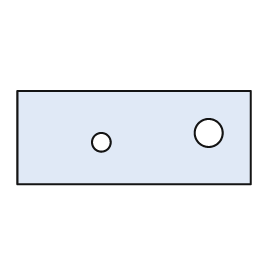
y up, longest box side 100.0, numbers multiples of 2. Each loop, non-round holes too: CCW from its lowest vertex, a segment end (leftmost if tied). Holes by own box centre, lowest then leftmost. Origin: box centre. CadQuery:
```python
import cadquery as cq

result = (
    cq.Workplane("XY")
    .moveTo(-50.0, -20.0)
    .lineTo(50.0, -20.0)
    .lineTo(50.0, 20.0)
    .lineTo(-50.0, 20.0)
    .close()
    .moveTo(-14.0, -2.0)
    .circle(4.0)
    .moveTo(32.0, 2.0)
    .circle(6.0)
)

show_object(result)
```